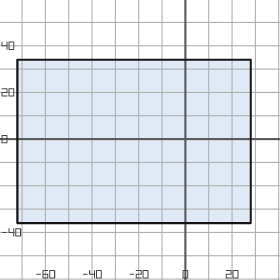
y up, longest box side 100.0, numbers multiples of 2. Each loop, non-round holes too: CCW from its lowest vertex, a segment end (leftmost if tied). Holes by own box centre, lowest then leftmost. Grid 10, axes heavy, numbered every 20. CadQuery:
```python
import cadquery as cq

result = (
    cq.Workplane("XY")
    .moveTo(-72.0, -36.0)
    .lineTo(28.0, -36.0)
    .lineTo(28.0, 34.0)
    .lineTo(-72.0, 34.0)
    .close()
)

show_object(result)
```